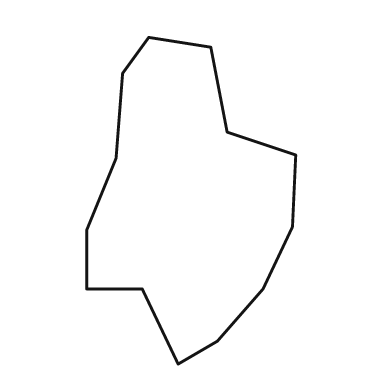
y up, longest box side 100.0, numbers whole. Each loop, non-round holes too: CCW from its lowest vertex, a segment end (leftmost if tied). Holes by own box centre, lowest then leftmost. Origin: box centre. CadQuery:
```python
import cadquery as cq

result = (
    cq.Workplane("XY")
    .moveTo(-4.0, -50.0)
    .lineTo(8.0, -43.0)
    .lineTo(22.0, -27.0)
    .lineTo(31.0, -8.0)
    .lineTo(32.0, 14.0)
    .lineTo(11.0, 21.0)
    .lineTo(6.0, 47.0)
    .lineTo(-13.0, 50.0)
    .lineTo(-21.0, 39.0)
    .lineTo(-23.0, 13.0)
    .lineTo(-32.0, -9.0)
    .lineTo(-32.0, -27.0)
    .lineTo(-15.0, -27.0)
    .close()
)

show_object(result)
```